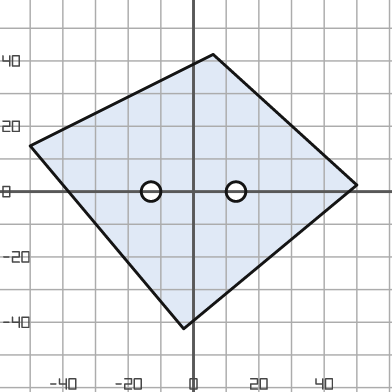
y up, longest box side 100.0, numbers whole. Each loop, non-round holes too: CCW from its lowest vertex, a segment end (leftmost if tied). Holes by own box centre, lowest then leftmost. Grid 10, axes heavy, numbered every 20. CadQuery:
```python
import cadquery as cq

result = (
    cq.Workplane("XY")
    .moveTo(-3.0, -42.0)
    .lineTo(50.0, 2.0)
    .lineTo(6.0, 42.0)
    .lineTo(-50.0, 14.0)
    .close()
    .moveTo(-13.0, 0.0)
    .circle(3.0)
    .moveTo(13.0, 0.0)
    .circle(3.0)
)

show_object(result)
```